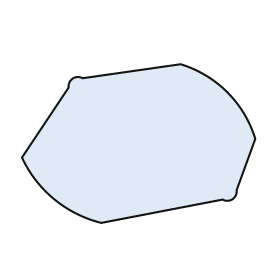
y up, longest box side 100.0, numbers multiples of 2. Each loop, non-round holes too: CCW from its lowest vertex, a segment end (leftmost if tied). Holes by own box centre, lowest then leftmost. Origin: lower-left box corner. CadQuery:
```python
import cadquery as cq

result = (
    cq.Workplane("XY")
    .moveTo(34.0, 0.0)
    .lineTo(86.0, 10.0)
    .threePointArc((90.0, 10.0), (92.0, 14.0))
    .lineTo(100.0, 36.0)
    .threePointArc((88.0, 56.0), (68.0, 68.0))
    .lineTo(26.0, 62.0)
    .threePointArc((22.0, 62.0), (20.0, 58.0))
    .lineTo(0.0, 28.0)
    .threePointArc((14.0, 10.0), (34.0, 0.0))
    .close()
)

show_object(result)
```